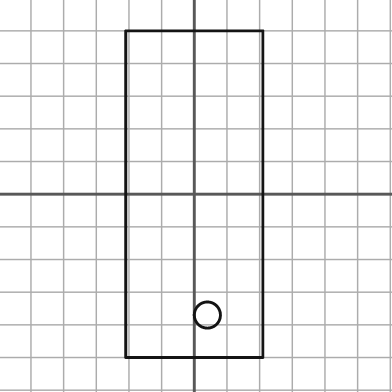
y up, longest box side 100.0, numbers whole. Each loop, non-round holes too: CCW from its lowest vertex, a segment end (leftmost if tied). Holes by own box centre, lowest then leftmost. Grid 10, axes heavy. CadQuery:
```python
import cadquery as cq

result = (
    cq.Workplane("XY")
    .moveTo(-21.0, -50.0)
    .lineTo(21.0, -50.0)
    .lineTo(21.0, 50.0)
    .lineTo(-21.0, 50.0)
    .close()
    .moveTo(4.0, -37.0)
    .circle(4.0)
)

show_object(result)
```